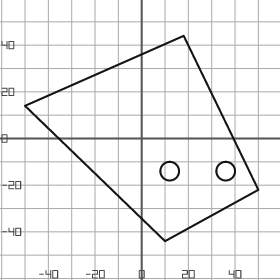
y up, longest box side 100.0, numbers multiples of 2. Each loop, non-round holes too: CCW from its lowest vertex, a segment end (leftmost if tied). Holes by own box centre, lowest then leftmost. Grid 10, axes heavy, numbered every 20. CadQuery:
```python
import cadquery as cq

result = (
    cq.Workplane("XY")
    .moveTo(10.0, -44.0)
    .lineTo(50.0, -22.0)
    .lineTo(18.0, 44.0)
    .lineTo(-50.0, 14.0)
    .close()
    .moveTo(12.0, -14.0)
    .circle(4.0)
    .moveTo(36.0, -14.0)
    .circle(4.0)
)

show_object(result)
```